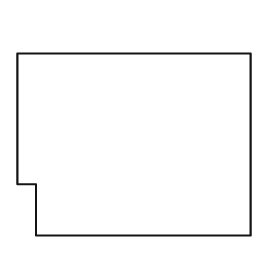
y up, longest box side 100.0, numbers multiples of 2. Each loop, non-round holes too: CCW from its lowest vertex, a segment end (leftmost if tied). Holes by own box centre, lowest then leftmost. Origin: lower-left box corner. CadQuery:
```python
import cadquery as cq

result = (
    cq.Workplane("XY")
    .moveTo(8.0, 0.0)
    .lineTo(100.0, 0.0)
    .lineTo(100.0, 78.0)
    .lineTo(0.0, 78.0)
    .lineTo(0.0, 22.0)
    .lineTo(8.0, 22.0)
    .close()
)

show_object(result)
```